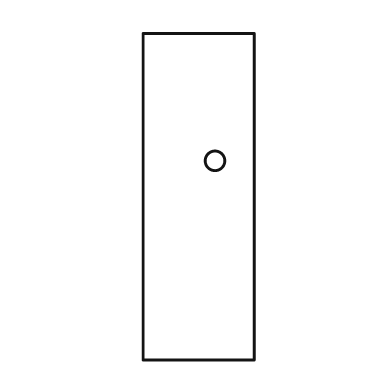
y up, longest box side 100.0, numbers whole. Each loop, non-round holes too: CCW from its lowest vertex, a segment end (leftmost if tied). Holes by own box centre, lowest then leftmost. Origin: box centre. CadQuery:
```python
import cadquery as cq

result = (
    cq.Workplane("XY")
    .moveTo(-17.0, -50.0)
    .lineTo(17.0, -50.0)
    .lineTo(17.0, 50.0)
    .lineTo(-17.0, 50.0)
    .close()
    .moveTo(5.0, 11.0)
    .circle(3.0)
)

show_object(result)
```